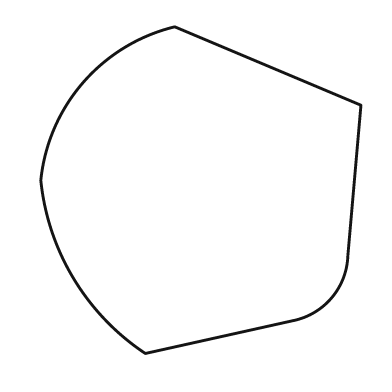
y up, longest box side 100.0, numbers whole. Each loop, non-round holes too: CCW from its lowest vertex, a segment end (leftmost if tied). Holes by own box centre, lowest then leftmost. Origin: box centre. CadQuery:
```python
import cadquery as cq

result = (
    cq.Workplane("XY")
    .moveTo(-17.0, -50.0)
    .lineTo(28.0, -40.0)
    .threePointArc((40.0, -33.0), (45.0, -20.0))
    .lineTo(49.0, 26.0)
    .lineTo(-8.0, 50.0)
    .threePointArc((-36.0, 33.0), (-49.0, 3.0))
    .threePointArc((-39.0, -27.0), (-17.0, -50.0))
    .close()
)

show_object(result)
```